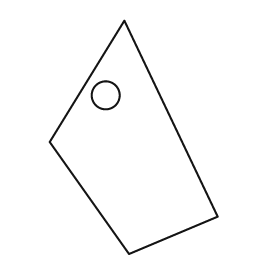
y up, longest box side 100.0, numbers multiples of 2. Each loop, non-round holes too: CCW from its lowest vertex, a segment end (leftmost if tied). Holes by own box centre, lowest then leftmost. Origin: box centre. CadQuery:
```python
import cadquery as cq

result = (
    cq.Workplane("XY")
    .moveTo(-2.0, -50.0)
    .lineTo(36.0, -34.0)
    .lineTo(-4.0, 50.0)
    .lineTo(-36.0, -2.0)
    .close()
    .moveTo(-12.0, 18.0)
    .circle(6.0)
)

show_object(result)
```